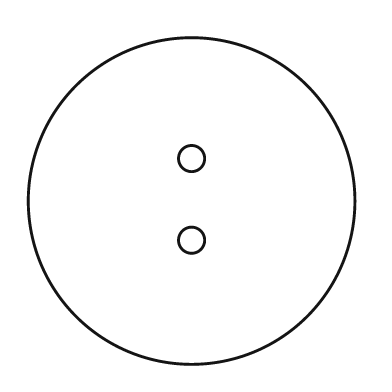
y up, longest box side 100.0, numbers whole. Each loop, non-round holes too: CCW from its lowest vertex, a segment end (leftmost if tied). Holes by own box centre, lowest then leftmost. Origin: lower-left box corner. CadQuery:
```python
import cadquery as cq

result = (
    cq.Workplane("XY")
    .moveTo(50.0, 50.0)
    .circle(50.0)
    .moveTo(50.0, 38.0)
    .circle(4.0)
    .moveTo(50.0, 63.0)
    .circle(4.0)
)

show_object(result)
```